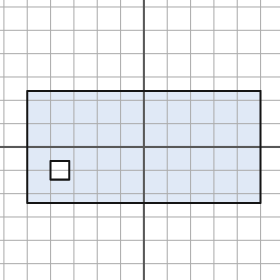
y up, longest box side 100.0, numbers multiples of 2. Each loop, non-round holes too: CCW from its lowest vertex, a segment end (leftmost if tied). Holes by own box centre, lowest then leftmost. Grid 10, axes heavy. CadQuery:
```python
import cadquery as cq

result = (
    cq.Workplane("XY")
    .moveTo(-50.0, -24.0)
    .lineTo(50.0, -24.0)
    .lineTo(50.0, 24.0)
    .lineTo(-50.0, 24.0)
    .close()
    .moveTo(-40.0, -14.0)
    .lineTo(-32.0, -14.0)
    .lineTo(-32.0, -6.0)
    .lineTo(-40.0, -6.0)
    .close()
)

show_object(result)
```